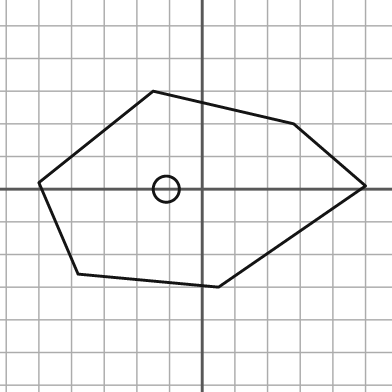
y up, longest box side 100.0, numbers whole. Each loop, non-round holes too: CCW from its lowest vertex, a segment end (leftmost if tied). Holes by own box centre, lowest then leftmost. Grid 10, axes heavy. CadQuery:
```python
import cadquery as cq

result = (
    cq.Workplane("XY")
    .moveTo(5.0, -30.0)
    .lineTo(50.0, 1.0)
    .lineTo(28.0, 20.0)
    .lineTo(-15.0, 30.0)
    .lineTo(-50.0, 2.0)
    .lineTo(-38.0, -26.0)
    .close()
    .moveTo(-11.0, 0.0)
    .circle(4.0)
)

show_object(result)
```